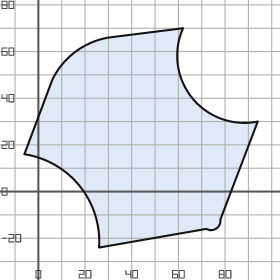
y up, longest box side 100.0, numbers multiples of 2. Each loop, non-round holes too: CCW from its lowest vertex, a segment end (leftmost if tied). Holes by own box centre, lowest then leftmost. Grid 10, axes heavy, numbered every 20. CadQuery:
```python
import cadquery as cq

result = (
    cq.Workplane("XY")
    .moveTo(26.0, -24.0)
    .lineTo(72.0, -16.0)
    .threePointArc((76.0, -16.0), (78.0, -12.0))
    .lineTo(94.0, 30.0)
    .threePointArc((66.0, 40.0), (62.0, 70.0))
    .lineTo(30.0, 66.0)
    .threePointArc((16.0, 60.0), (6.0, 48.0))
    .lineTo(-6.0, 16.0)
    .threePointArc((18.0, 2.0), (26.0, -24.0))
    .close()
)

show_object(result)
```